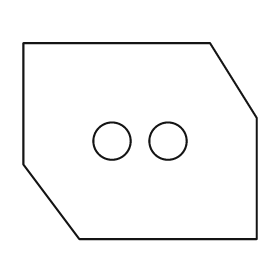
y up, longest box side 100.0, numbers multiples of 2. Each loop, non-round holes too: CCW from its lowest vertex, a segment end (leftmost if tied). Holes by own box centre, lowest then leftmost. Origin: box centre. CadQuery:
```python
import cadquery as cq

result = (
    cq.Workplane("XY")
    .moveTo(-26.0, -42.0)
    .lineTo(50.0, -42.0)
    .lineTo(50.0, 10.0)
    .lineTo(30.0, 42.0)
    .lineTo(-50.0, 42.0)
    .lineTo(-50.0, -10.0)
    .close()
    .moveTo(-12.0, 0.0)
    .circle(8.0)
    .moveTo(12.0, 0.0)
    .circle(8.0)
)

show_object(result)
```